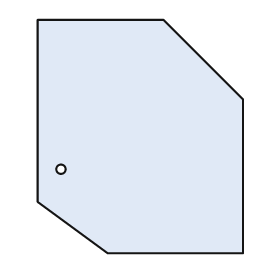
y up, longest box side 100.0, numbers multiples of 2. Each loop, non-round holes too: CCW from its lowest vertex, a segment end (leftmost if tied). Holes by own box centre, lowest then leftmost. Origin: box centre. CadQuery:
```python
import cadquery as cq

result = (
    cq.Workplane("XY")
    .moveTo(-14.0, -50.0)
    .lineTo(44.0, -50.0)
    .lineTo(44.0, 16.0)
    .lineTo(10.0, 50.0)
    .lineTo(-44.0, 50.0)
    .lineTo(-44.0, -28.0)
    .close()
    .moveTo(-34.0, -14.0)
    .circle(2.0)
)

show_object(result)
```